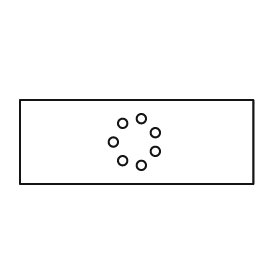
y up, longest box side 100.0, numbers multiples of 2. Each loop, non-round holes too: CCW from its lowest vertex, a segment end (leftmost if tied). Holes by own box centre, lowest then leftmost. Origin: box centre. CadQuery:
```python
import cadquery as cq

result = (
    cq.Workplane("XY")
    .moveTo(-50.0, -18.0)
    .lineTo(50.0, -18.0)
    .lineTo(50.0, 18.0)
    .lineTo(-50.0, 18.0)
    .close()
    .moveTo(2.0, -10.0)
    .circle(2.0)
    .moveTo(-6.0, -8.0)
    .circle(2.0)
    .moveTo(8.0, -4.0)
    .circle(2.0)
    .moveTo(-10.0, 0.0)
    .circle(2.0)
    .moveTo(8.0, 4.0)
    .circle(2.0)
    .moveTo(-6.0, 8.0)
    .circle(2.0)
    .moveTo(2.0, 10.0)
    .circle(2.0)
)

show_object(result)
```